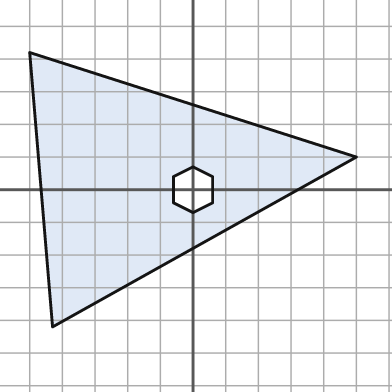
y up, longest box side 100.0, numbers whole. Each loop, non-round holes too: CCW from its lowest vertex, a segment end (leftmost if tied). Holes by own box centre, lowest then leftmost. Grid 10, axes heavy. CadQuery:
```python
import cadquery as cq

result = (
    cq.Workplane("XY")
    .moveTo(-43.0, -42.0)
    .lineTo(50.0, 10.0)
    .lineTo(-50.0, 42.0)
    .close()
    .moveTo(0.0, -7.0)
    .lineTo(6.0, -4.0)
    .lineTo(6.0, 4.0)
    .lineTo(0.0, 7.0)
    .lineTo(-6.0, 4.0)
    .lineTo(-6.0, -4.0)
    .close()
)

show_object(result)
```